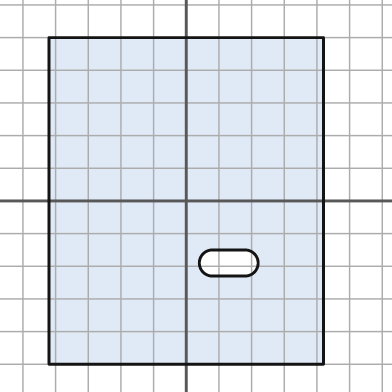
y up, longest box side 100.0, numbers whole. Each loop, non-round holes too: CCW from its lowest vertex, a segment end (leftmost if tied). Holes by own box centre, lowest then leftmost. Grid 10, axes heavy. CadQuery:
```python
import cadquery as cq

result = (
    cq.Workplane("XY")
    .moveTo(-42.0, -50.0)
    .lineTo(42.0, -50.0)
    .lineTo(42.0, 50.0)
    .lineTo(-42.0, 50.0)
    .close()
    .moveTo(8.0, -23.0)
    .lineTo(18.0, -23.0)
    .threePointArc((22.0, -19.0), (18.0, -15.0))
    .lineTo(8.0, -15.0)
    .threePointArc((4.0, -19.0), (8.0, -23.0))
    .close()
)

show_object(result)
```